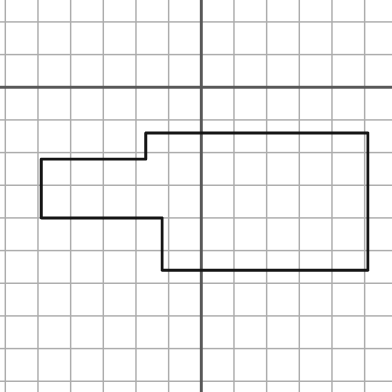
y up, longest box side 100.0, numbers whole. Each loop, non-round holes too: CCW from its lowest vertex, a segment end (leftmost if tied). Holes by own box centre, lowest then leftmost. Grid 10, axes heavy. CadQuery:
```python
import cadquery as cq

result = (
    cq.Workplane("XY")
    .moveTo(-12.0, -56.0)
    .lineTo(51.0, -56.0)
    .lineTo(51.0, -14.0)
    .lineTo(-17.0, -14.0)
    .lineTo(-17.0, -22.0)
    .lineTo(-49.0, -22.0)
    .lineTo(-49.0, -40.0)
    .lineTo(-12.0, -40.0)
    .close()
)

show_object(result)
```